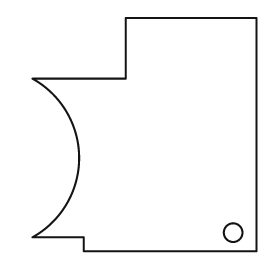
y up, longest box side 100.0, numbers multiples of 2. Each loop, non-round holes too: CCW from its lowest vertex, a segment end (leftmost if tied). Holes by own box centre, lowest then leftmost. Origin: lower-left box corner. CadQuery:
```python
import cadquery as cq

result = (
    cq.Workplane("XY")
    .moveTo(22.0, 0.0)
    .lineTo(96.0, 0.0)
    .lineTo(96.0, 100.0)
    .lineTo(40.0, 100.0)
    .lineTo(40.0, 74.0)
    .lineTo(0.0, 74.0)
    .threePointArc((20.0, 40.0), (0.0, 6.0))
    .lineTo(22.0, 6.0)
    .close()
    .moveTo(86.0, 8.0)
    .circle(4.0)
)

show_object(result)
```